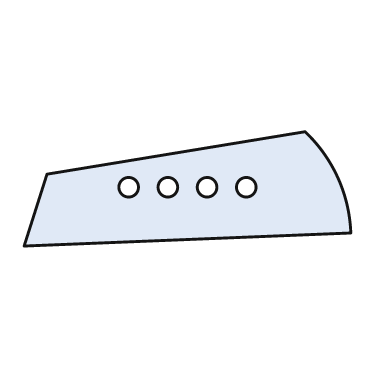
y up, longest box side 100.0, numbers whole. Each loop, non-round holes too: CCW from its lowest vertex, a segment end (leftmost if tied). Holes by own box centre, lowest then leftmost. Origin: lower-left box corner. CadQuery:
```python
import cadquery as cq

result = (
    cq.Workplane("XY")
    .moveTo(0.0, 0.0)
    .lineTo(100.0, 4.0)
    .threePointArc((96.0, 21.0), (86.0, 35.0))
    .lineTo(7.0, 22.0)
    .close()
    .moveTo(32.0, 18.0)
    .circle(3.0)
    .moveTo(44.0, 18.0)
    .circle(3.0)
    .moveTo(56.0, 18.0)
    .circle(3.0)
    .moveTo(68.0, 18.0)
    .circle(3.0)
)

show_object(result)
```